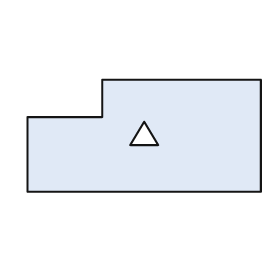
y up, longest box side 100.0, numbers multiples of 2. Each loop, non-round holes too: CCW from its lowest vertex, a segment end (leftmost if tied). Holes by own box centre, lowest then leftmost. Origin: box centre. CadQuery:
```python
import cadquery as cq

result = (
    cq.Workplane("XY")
    .moveTo(-50.0, -24.0)
    .lineTo(50.0, -24.0)
    .lineTo(50.0, 24.0)
    .lineTo(-18.0, 24.0)
    .lineTo(-18.0, 8.0)
    .lineTo(-50.0, 8.0)
    .close()
    .moveTo(-6.0, -4.0)
    .lineTo(6.0, -4.0)
    .lineTo(0.0, 6.0)
    .close()
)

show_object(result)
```